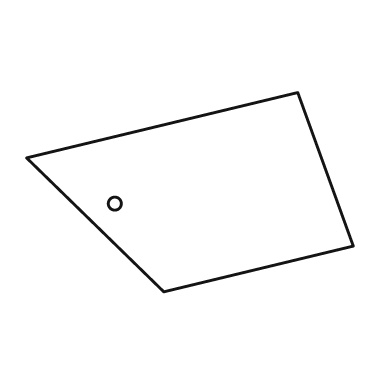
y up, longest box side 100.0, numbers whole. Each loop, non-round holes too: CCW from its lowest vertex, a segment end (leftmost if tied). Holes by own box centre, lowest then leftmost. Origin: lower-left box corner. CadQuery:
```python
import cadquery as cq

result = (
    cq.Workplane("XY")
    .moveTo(42.0, 0.0)
    .lineTo(100.0, 14.0)
    .lineTo(83.0, 61.0)
    .lineTo(0.0, 41.0)
    .close()
    .moveTo(27.0, 27.0)
    .circle(2.0)
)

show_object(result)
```